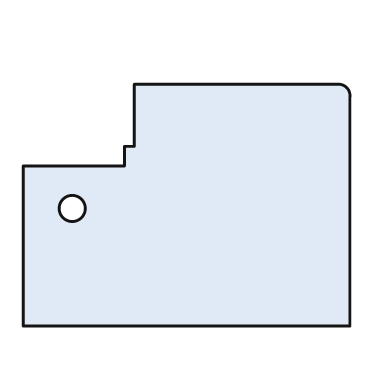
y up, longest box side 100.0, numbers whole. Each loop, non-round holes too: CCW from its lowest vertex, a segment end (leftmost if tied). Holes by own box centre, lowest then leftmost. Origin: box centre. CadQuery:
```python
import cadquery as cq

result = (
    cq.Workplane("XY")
    .moveTo(-50.0, -37.0)
    .lineTo(50.0, -37.0)
    .lineTo(50.0, 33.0)
    .threePointArc((49.0, 36.0), (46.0, 37.0))
    .lineTo(-16.0, 37.0)
    .lineTo(-16.0, 18.0)
    .lineTo(-19.0, 18.0)
    .lineTo(-19.0, 12.0)
    .lineTo(-50.0, 12.0)
    .close()
    .moveTo(-35.0, -1.0)
    .circle(4.0)
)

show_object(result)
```